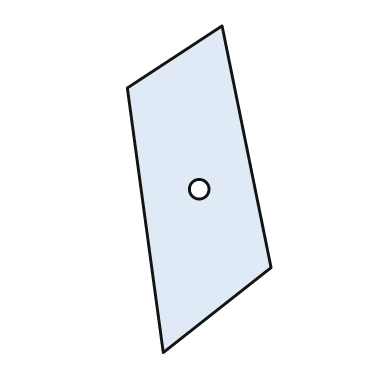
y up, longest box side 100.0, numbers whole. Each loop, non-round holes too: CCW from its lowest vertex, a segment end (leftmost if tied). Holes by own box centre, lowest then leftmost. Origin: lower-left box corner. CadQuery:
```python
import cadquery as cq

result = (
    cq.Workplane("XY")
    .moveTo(11.0, 0.0)
    .lineTo(44.0, 26.0)
    .lineTo(29.0, 100.0)
    .lineTo(0.0, 81.0)
    .close()
    .moveTo(22.0, 50.0)
    .circle(3.0)
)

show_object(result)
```